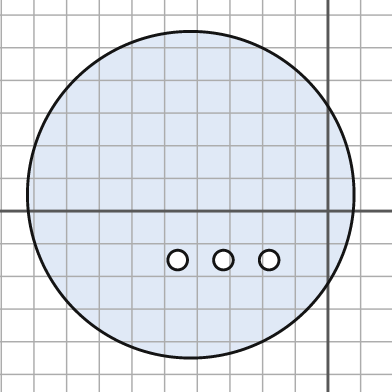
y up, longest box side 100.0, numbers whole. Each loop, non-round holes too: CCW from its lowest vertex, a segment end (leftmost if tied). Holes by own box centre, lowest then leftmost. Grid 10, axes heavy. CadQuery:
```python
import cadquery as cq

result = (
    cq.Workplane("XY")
    .moveTo(-42.0, 5.0)
    .circle(50.0)
    .moveTo(-46.0, -15.0)
    .circle(3.0)
    .moveTo(-32.0, -15.0)
    .circle(3.0)
    .moveTo(-18.0, -15.0)
    .circle(3.0)
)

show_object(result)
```